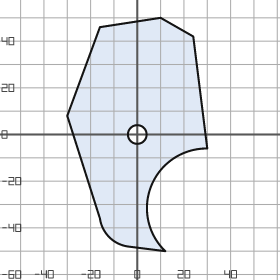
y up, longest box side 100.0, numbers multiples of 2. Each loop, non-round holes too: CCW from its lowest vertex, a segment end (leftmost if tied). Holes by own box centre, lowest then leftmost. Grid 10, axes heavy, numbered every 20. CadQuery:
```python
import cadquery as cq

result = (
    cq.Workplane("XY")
    .moveTo(12.0, -50.0)
    .threePointArc((6.0, -22.0), (30.0, -6.0))
    .lineTo(24.0, 42.0)
    .lineTo(10.0, 50.0)
    .lineTo(-16.0, 46.0)
    .lineTo(-30.0, 8.0)
    .lineTo(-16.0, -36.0)
    .threePointArc((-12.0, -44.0), (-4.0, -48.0))
    .close()
    .moveTo(0.0, 0.0)
    .circle(4.0)
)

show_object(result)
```